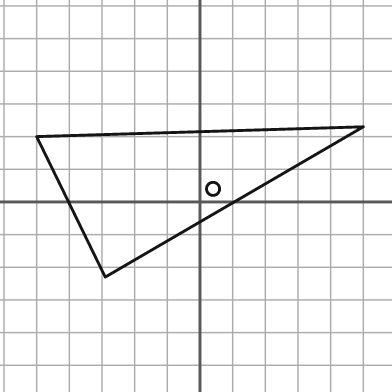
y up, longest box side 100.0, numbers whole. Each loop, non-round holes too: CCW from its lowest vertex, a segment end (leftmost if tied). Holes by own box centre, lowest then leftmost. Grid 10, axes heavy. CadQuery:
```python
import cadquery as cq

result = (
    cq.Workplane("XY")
    .moveTo(-29.0, -23.0)
    .lineTo(50.0, 23.0)
    .lineTo(-50.0, 20.0)
    .close()
    .moveTo(4.0, 4.0)
    .circle(2.0)
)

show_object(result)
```